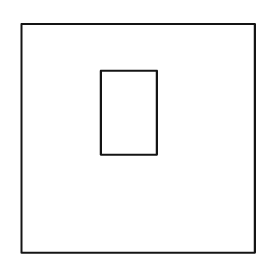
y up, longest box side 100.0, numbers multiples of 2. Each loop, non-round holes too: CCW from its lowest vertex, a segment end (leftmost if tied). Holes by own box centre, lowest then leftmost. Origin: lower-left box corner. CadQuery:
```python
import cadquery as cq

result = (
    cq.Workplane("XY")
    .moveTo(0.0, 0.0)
    .lineTo(100.0, 0.0)
    .lineTo(100.0, 98.0)
    .lineTo(0.0, 98.0)
    .close()
    .moveTo(34.0, 42.0)
    .lineTo(58.0, 42.0)
    .lineTo(58.0, 78.0)
    .lineTo(34.0, 78.0)
    .close()
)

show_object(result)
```